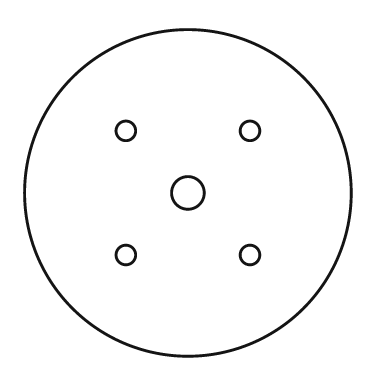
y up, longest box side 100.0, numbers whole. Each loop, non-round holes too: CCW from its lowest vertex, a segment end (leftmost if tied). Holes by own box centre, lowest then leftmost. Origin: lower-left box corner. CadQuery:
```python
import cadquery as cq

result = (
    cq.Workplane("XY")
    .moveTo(50.0, 50.0)
    .circle(50.0)
    .moveTo(31.0, 31.0)
    .circle(3.0)
    .moveTo(69.0, 31.0)
    .circle(3.0)
    .moveTo(50.0, 50.0)
    .circle(5.0)
    .moveTo(31.0, 69.0)
    .circle(3.0)
    .moveTo(69.0, 69.0)
    .circle(3.0)
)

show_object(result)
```